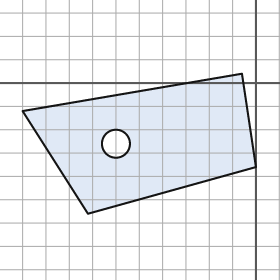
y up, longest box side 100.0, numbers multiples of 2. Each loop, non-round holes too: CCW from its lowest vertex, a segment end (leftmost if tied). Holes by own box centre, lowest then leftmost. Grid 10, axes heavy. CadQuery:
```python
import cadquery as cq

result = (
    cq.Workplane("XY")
    .moveTo(-72.0, -56.0)
    .lineTo(0.0, -36.0)
    .lineTo(-6.0, 4.0)
    .lineTo(-100.0, -12.0)
    .close()
    .moveTo(-60.0, -26.0)
    .circle(6.0)
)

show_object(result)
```